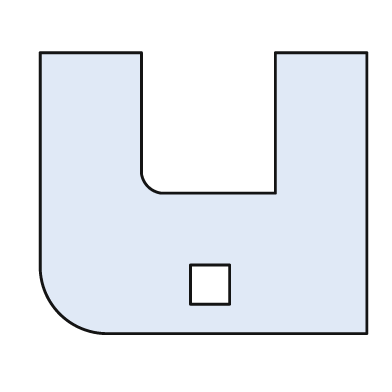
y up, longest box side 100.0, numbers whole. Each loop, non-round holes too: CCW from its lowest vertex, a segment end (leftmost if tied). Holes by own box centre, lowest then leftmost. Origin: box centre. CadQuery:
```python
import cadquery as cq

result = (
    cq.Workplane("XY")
    .moveTo(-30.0, -43.0)
    .lineTo(50.0, -43.0)
    .lineTo(50.0, 43.0)
    .lineTo(22.0, 43.0)
    .lineTo(22.0, 0.0)
    .lineTo(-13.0, 0.0)
    .threePointArc((-17.0, 2.0), (-19.0, 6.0))
    .lineTo(-19.0, 43.0)
    .lineTo(-50.0, 43.0)
    .lineTo(-50.0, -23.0)
    .threePointArc((-44.0, -37.0), (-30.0, -43.0))
    .close()
    .moveTo(-4.0, -34.0)
    .lineTo(8.0, -34.0)
    .lineTo(8.0, -22.0)
    .lineTo(-4.0, -22.0)
    .close()
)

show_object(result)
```